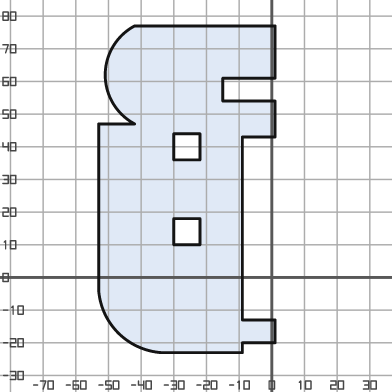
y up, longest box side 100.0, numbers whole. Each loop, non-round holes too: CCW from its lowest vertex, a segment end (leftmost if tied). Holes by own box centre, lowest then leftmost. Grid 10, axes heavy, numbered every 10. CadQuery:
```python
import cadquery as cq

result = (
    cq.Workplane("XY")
    .moveTo(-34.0, -23.0)
    .lineTo(-9.0, -23.0)
    .lineTo(-9.0, -20.0)
    .lineTo(1.0, -20.0)
    .lineTo(1.0, -13.0)
    .lineTo(-9.0, -13.0)
    .lineTo(-9.0, 43.0)
    .lineTo(1.0, 43.0)
    .lineTo(1.0, 54.0)
    .lineTo(-15.0, 54.0)
    .lineTo(-15.0, 61.0)
    .lineTo(1.0, 61.0)
    .lineTo(1.0, 77.0)
    .lineTo(-42.0, 77.0)
    .threePointArc((-51.0, 62.0), (-42.0, 47.0))
    .lineTo(-53.0, 47.0)
    .lineTo(-53.0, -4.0)
    .threePointArc((-47.0, -17.0), (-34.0, -23.0))
    .close()
    .moveTo(-30.0, 10.0)
    .lineTo(-22.0, 10.0)
    .lineTo(-22.0, 18.0)
    .lineTo(-30.0, 18.0)
    .close()
    .moveTo(-30.0, 36.0)
    .lineTo(-22.0, 36.0)
    .lineTo(-22.0, 44.0)
    .lineTo(-30.0, 44.0)
    .close()
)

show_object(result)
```